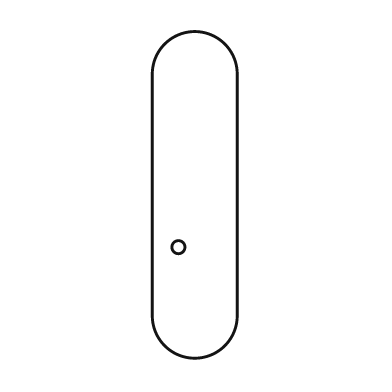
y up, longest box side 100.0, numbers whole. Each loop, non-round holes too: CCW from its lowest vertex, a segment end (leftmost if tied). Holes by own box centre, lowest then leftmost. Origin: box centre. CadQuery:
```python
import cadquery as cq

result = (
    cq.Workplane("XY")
    .moveTo(-13.0, -37.0)
    .threePointArc((0.0, -50.0), (13.0, -37.0))
    .lineTo(13.0, 37.0)
    .threePointArc((0.0, 50.0), (-13.0, 37.0))
    .close()
    .moveTo(-5.0, -16.0)
    .circle(2.0)
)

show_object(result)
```